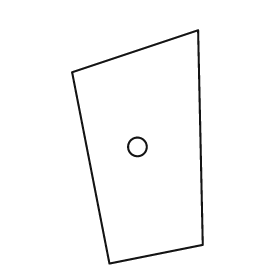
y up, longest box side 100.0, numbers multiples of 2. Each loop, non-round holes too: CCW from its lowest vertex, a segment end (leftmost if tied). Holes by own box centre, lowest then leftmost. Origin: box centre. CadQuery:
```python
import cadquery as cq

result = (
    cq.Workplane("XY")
    .moveTo(-12.0, -50.0)
    .lineTo(28.0, -42.0)
    .lineTo(26.0, 50.0)
    .lineTo(-28.0, 32.0)
    .close()
    .moveTo(0.0, 0.0)
    .circle(4.0)
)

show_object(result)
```